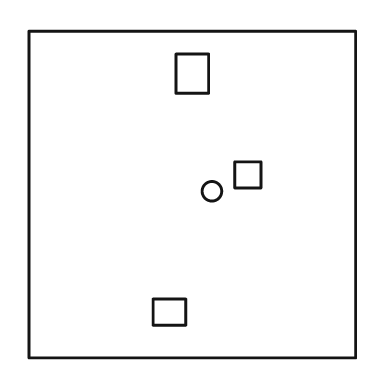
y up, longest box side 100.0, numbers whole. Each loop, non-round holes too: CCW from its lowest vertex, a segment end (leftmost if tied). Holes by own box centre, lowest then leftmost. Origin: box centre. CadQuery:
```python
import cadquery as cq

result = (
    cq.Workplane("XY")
    .moveTo(-50.0, -50.0)
    .lineTo(50.0, -50.0)
    .lineTo(50.0, 50.0)
    .lineTo(-50.0, 50.0)
    .close()
    .moveTo(-12.0, -40.0)
    .lineTo(-2.0, -40.0)
    .lineTo(-2.0, -32.0)
    .lineTo(-12.0, -32.0)
    .close()
    .moveTo(6.0, 1.0)
    .circle(3.0)
    .moveTo(13.0, 2.0)
    .lineTo(21.0, 2.0)
    .lineTo(21.0, 10.0)
    .lineTo(13.0, 10.0)
    .close()
    .moveTo(-5.0, 31.0)
    .lineTo(5.0, 31.0)
    .lineTo(5.0, 43.0)
    .lineTo(-5.0, 43.0)
    .close()
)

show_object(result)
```